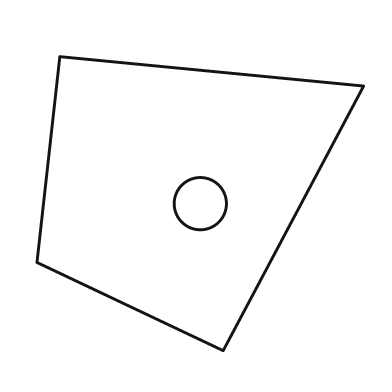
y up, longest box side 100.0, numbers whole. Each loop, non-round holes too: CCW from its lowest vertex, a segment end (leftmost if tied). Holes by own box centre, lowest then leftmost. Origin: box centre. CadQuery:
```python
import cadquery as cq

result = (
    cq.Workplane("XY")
    .moveTo(7.0, -45.0)
    .lineTo(50.0, 36.0)
    .lineTo(-43.0, 45.0)
    .lineTo(-50.0, -18.0)
    .close()
    .moveTo(0.0, 0.0)
    .circle(8.0)
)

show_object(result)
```